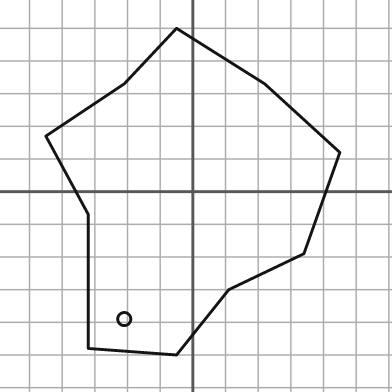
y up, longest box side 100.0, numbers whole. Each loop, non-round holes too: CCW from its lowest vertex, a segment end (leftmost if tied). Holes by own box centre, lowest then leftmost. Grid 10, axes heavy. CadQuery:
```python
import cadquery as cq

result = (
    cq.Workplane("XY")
    .moveTo(-5.0, -50.0)
    .lineTo(11.0, -30.0)
    .lineTo(34.0, -19.0)
    .lineTo(45.0, 12.0)
    .lineTo(22.0, 33.0)
    .lineTo(-5.0, 50.0)
    .lineTo(-21.0, 33.0)
    .lineTo(-45.0, 17.0)
    .lineTo(-32.0, -7.0)
    .lineTo(-32.0, -48.0)
    .close()
    .moveTo(-21.0, -39.0)
    .circle(2.0)
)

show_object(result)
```